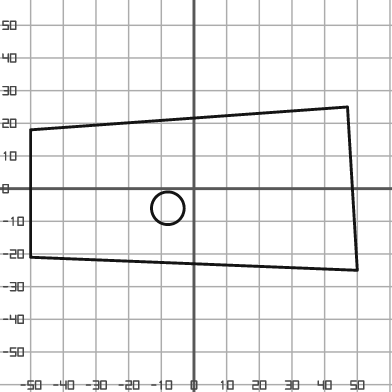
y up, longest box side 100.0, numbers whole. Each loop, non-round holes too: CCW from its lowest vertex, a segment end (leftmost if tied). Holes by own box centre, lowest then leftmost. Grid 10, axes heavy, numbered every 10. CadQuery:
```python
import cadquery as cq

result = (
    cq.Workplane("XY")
    .moveTo(50.0, -25.0)
    .lineTo(47.0, 25.0)
    .lineTo(-50.0, 18.0)
    .lineTo(-50.0, -21.0)
    .close()
    .moveTo(-8.0, -6.0)
    .circle(5.0)
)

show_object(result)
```